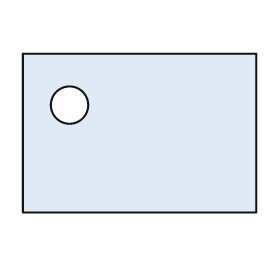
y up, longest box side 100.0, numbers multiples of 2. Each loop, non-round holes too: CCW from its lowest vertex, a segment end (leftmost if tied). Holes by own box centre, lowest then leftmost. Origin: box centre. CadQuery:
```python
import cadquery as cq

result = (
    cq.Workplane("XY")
    .moveTo(-50.0, -34.0)
    .lineTo(50.0, -34.0)
    .lineTo(50.0, 34.0)
    .lineTo(-50.0, 34.0)
    .close()
    .moveTo(-30.0, 12.0)
    .circle(8.0)
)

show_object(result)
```